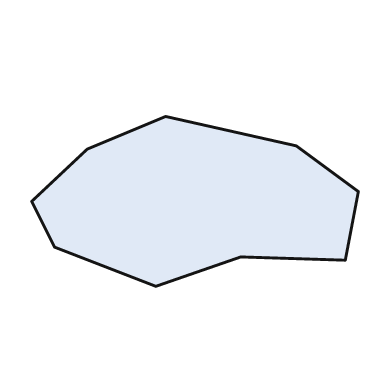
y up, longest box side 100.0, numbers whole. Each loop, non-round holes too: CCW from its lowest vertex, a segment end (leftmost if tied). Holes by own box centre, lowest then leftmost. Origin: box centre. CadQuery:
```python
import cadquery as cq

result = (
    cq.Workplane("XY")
    .moveTo(-12.0, -26.0)
    .lineTo(14.0, -17.0)
    .lineTo(46.0, -18.0)
    .lineTo(50.0, 3.0)
    .lineTo(31.0, 17.0)
    .lineTo(-9.0, 26.0)
    .lineTo(-33.0, 16.0)
    .lineTo(-50.0, 0.0)
    .lineTo(-43.0, -14.0)
    .close()
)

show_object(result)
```